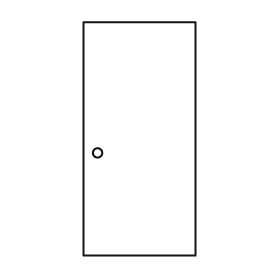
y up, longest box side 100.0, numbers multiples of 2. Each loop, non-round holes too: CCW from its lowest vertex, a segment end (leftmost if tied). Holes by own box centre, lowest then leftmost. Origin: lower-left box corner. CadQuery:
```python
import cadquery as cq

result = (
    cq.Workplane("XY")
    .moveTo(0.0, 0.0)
    .lineTo(48.0, 0.0)
    .lineTo(48.0, 100.0)
    .lineTo(0.0, 100.0)
    .close()
    .moveTo(6.0, 44.0)
    .circle(2.0)
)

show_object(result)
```